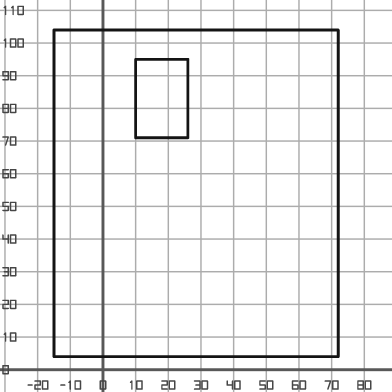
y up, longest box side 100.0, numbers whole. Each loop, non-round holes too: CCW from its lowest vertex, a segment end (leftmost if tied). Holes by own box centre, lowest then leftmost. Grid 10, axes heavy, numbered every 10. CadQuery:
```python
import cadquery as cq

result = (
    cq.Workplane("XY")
    .moveTo(-15.0, 4.0)
    .lineTo(72.0, 4.0)
    .lineTo(72.0, 104.0)
    .lineTo(-15.0, 104.0)
    .close()
    .moveTo(10.0, 71.0)
    .lineTo(26.0, 71.0)
    .lineTo(26.0, 95.0)
    .lineTo(10.0, 95.0)
    .close()
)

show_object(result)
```